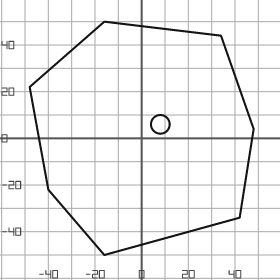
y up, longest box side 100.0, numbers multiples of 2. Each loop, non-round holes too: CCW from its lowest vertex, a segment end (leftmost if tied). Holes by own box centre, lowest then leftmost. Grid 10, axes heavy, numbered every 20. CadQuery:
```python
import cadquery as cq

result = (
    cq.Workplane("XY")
    .moveTo(-16.0, -50.0)
    .lineTo(42.0, -34.0)
    .lineTo(48.0, 4.0)
    .lineTo(34.0, 44.0)
    .lineTo(-16.0, 50.0)
    .lineTo(-48.0, 22.0)
    .lineTo(-40.0, -22.0)
    .close()
    .moveTo(8.0, 6.0)
    .circle(4.0)
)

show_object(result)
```